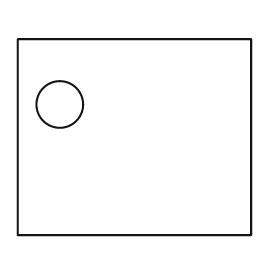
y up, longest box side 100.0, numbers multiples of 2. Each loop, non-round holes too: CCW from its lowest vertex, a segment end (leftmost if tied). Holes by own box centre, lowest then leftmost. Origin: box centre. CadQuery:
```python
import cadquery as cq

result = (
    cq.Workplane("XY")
    .moveTo(-50.0, -42.0)
    .lineTo(50.0, -42.0)
    .lineTo(50.0, 42.0)
    .lineTo(-50.0, 42.0)
    .close()
    .moveTo(-32.0, 14.0)
    .circle(10.0)
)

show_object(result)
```